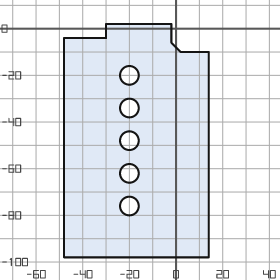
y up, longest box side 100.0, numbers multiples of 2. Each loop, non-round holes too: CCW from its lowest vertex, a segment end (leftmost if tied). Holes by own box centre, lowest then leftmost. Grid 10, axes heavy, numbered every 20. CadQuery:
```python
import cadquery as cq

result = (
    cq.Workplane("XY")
    .moveTo(-48.0, -98.0)
    .lineTo(14.0, -98.0)
    .lineTo(14.0, -10.0)
    .lineTo(2.0, -10.0)
    .lineTo(-2.0, -6.0)
    .lineTo(-2.0, 2.0)
    .lineTo(-30.0, 2.0)
    .lineTo(-30.0, -4.0)
    .lineTo(-48.0, -4.0)
    .close()
    .moveTo(-20.0, -76.0)
    .circle(4.0)
    .moveTo(-20.0, -62.0)
    .circle(4.0)
    .moveTo(-20.0, -48.0)
    .circle(4.0)
    .moveTo(-20.0, -34.0)
    .circle(4.0)
    .moveTo(-20.0, -20.0)
    .circle(4.0)
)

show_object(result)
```